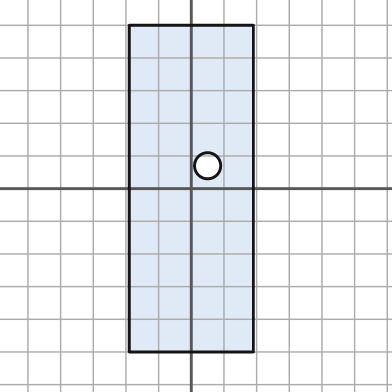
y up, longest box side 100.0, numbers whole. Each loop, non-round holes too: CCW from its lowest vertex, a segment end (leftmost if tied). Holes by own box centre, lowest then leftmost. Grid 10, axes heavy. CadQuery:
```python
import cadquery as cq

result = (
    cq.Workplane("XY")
    .moveTo(-19.0, -50.0)
    .lineTo(19.0, -50.0)
    .lineTo(19.0, 50.0)
    .lineTo(-19.0, 50.0)
    .close()
    .moveTo(5.0, 7.0)
    .circle(4.0)
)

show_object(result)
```